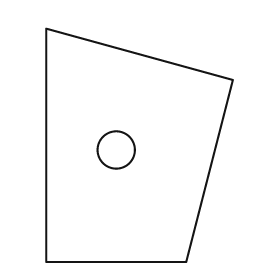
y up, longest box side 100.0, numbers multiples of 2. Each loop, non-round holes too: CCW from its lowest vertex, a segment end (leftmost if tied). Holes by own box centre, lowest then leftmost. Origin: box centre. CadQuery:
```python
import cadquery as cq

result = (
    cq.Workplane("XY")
    .moveTo(-40.0, -50.0)
    .lineTo(20.0, -50.0)
    .lineTo(40.0, 28.0)
    .lineTo(-40.0, 50.0)
    .close()
    .moveTo(-10.0, -2.0)
    .circle(8.0)
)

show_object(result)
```